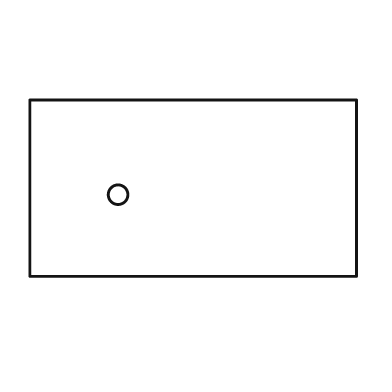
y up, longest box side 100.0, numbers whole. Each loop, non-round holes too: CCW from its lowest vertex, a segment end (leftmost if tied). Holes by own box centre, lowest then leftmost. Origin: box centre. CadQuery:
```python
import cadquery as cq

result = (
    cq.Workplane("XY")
    .moveTo(-50.0, -27.0)
    .lineTo(50.0, -27.0)
    .lineTo(50.0, 27.0)
    .lineTo(-50.0, 27.0)
    .close()
    .moveTo(-23.0, -2.0)
    .circle(3.0)
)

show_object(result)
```